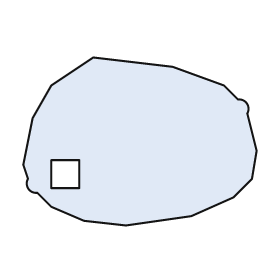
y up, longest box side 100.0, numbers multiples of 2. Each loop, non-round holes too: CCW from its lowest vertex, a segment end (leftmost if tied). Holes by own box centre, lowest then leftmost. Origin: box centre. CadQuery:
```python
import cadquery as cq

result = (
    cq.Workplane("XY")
    .moveTo(-6.0, -36.0)
    .lineTo(22.0, -32.0)
    .lineTo(40.0, -24.0)
    .lineTo(48.0, -16.0)
    .lineTo(50.0, -4.0)
    .lineTo(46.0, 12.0)
    .threePointArc((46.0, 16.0), (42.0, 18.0))
    .lineTo(36.0, 24.0)
    .lineTo(14.0, 32.0)
    .lineTo(-20.0, 36.0)
    .lineTo(-38.0, 24.0)
    .lineTo(-46.0, 10.0)
    .lineTo(-50.0, -10.0)
    .lineTo(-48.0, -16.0)
    .threePointArc((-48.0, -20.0), (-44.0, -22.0))
    .lineTo(-38.0, -28.0)
    .lineTo(-24.0, -34.0)
    .close()
    .moveTo(-38.0, -20.0)
    .lineTo(-26.0, -20.0)
    .lineTo(-26.0, -8.0)
    .lineTo(-38.0, -8.0)
    .close()
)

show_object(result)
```